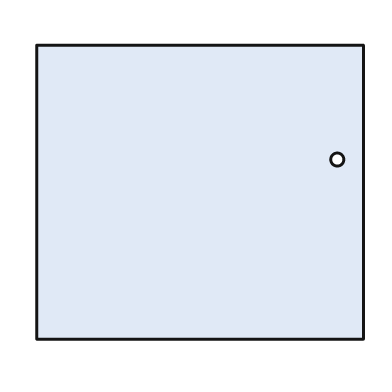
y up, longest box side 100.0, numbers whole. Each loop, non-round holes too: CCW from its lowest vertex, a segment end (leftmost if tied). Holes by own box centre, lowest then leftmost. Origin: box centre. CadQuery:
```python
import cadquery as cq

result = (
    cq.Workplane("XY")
    .moveTo(-50.0, -45.0)
    .lineTo(50.0, -45.0)
    .lineTo(50.0, 45.0)
    .lineTo(-50.0, 45.0)
    .close()
    .moveTo(42.0, 10.0)
    .circle(2.0)
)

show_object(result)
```